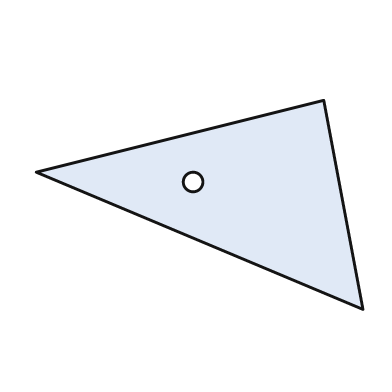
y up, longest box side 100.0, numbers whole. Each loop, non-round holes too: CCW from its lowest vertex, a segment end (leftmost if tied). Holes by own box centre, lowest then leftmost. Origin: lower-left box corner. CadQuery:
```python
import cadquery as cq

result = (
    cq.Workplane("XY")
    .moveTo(100.0, 0.0)
    .lineTo(88.0, 64.0)
    .lineTo(0.0, 42.0)
    .close()
    .moveTo(48.0, 39.0)
    .circle(3.0)
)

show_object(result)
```